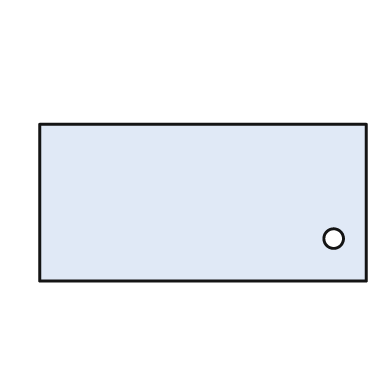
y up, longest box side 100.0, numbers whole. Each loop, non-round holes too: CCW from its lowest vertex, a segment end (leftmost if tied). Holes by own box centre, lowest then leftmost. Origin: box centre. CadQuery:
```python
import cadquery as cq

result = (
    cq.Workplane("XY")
    .moveTo(-50.0, -24.0)
    .lineTo(50.0, -24.0)
    .lineTo(50.0, 24.0)
    .lineTo(-50.0, 24.0)
    .close()
    .moveTo(40.0, -11.0)
    .circle(3.0)
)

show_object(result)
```